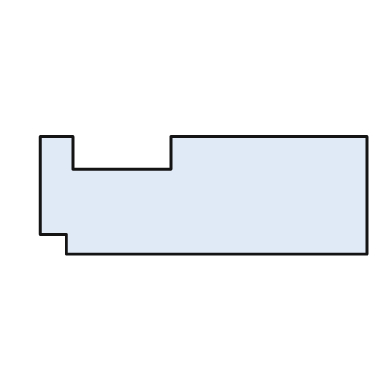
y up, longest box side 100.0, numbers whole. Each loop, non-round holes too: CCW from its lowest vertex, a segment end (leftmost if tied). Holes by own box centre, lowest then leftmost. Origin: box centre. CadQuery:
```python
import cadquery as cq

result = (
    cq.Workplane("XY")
    .moveTo(-42.0, -18.0)
    .lineTo(50.0, -18.0)
    .lineTo(50.0, 18.0)
    .lineTo(-10.0, 18.0)
    .lineTo(-10.0, 8.0)
    .lineTo(-40.0, 8.0)
    .lineTo(-40.0, 18.0)
    .lineTo(-50.0, 18.0)
    .lineTo(-50.0, -12.0)
    .lineTo(-42.0, -12.0)
    .close()
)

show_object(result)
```